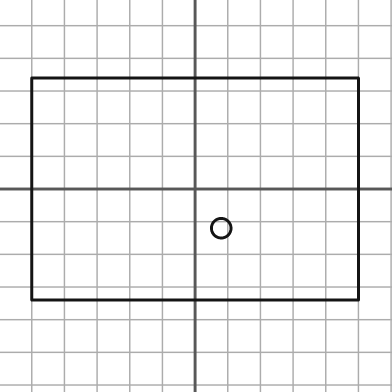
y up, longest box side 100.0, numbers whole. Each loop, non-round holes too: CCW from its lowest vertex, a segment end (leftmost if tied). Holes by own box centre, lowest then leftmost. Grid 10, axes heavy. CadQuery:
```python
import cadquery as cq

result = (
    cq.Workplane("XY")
    .moveTo(-50.0, -34.0)
    .lineTo(50.0, -34.0)
    .lineTo(50.0, 34.0)
    .lineTo(-50.0, 34.0)
    .close()
    .moveTo(8.0, -12.0)
    .circle(3.0)
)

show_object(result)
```